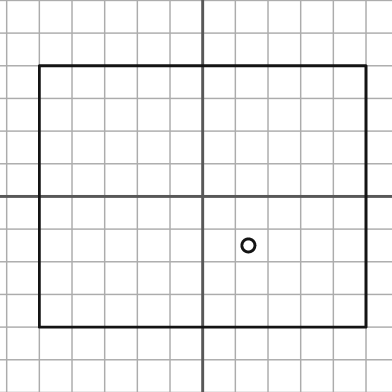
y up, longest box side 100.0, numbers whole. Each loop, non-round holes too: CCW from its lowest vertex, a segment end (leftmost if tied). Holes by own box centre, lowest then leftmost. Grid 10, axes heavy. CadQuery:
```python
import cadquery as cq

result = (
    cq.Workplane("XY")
    .moveTo(-50.0, -40.0)
    .lineTo(50.0, -40.0)
    .lineTo(50.0, 40.0)
    .lineTo(-50.0, 40.0)
    .close()
    .moveTo(14.0, -15.0)
    .circle(2.0)
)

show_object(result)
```